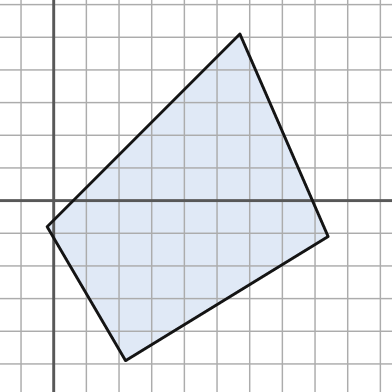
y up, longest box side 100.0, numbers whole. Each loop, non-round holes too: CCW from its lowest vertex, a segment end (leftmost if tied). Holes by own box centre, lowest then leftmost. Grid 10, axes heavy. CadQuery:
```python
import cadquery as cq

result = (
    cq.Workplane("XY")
    .moveTo(22.0, -49.0)
    .lineTo(84.0, -11.0)
    .lineTo(57.0, 51.0)
    .lineTo(-2.0, -8.0)
    .close()
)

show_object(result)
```